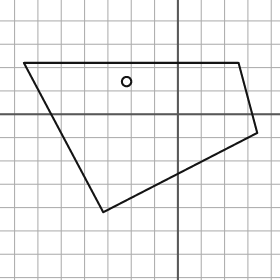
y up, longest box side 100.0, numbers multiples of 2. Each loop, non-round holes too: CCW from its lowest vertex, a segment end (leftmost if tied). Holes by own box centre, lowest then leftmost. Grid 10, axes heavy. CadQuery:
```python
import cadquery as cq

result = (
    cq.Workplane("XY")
    .moveTo(-32.0, -42.0)
    .lineTo(34.0, -8.0)
    .lineTo(26.0, 22.0)
    .lineTo(-66.0, 22.0)
    .close()
    .moveTo(-22.0, 14.0)
    .circle(2.0)
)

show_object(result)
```